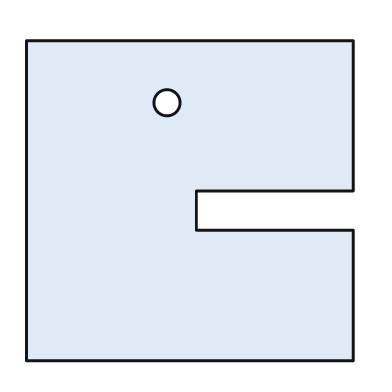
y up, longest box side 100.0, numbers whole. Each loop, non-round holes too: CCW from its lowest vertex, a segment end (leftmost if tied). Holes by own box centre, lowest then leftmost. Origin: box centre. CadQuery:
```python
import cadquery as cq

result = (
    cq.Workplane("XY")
    .moveTo(-50.0, -49.0)
    .lineTo(50.0, -49.0)
    .lineTo(50.0, -9.0)
    .lineTo(2.0, -9.0)
    .lineTo(2.0, 3.0)
    .lineTo(50.0, 3.0)
    .lineTo(50.0, 49.0)
    .lineTo(-50.0, 49.0)
    .close()
    .moveTo(-7.0, 30.0)
    .circle(4.0)
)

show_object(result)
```